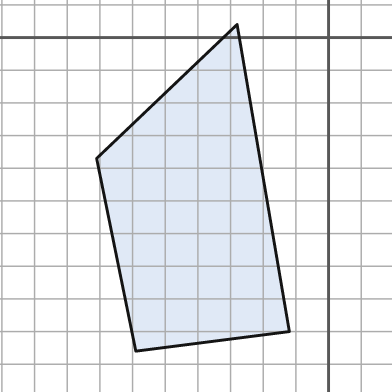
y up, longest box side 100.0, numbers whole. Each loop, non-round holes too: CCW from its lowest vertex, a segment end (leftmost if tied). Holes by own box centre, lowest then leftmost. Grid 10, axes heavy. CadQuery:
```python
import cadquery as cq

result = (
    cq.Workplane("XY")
    .moveTo(-59.0, -96.0)
    .lineTo(-12.0, -90.0)
    .lineTo(-28.0, 4.0)
    .lineTo(-71.0, -37.0)
    .close()
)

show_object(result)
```